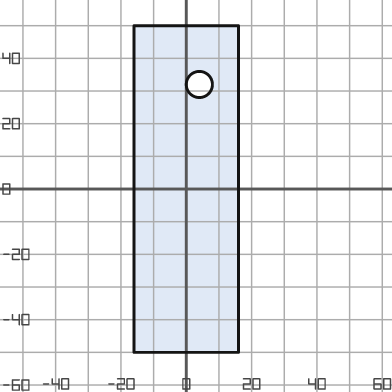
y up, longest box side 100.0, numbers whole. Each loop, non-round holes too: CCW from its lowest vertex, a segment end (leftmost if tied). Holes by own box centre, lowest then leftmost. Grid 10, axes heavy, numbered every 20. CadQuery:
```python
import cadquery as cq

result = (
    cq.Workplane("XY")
    .moveTo(-16.0, -50.0)
    .lineTo(16.0, -50.0)
    .lineTo(16.0, 50.0)
    .lineTo(-16.0, 50.0)
    .close()
    .moveTo(4.0, 32.0)
    .circle(4.0)
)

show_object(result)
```